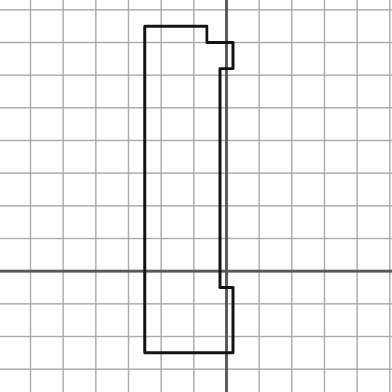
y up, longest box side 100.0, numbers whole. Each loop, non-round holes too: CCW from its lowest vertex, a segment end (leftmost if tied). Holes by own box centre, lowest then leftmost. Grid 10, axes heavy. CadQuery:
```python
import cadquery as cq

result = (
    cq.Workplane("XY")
    .moveTo(-25.0, -25.0)
    .lineTo(2.0, -25.0)
    .lineTo(2.0, -5.0)
    .lineTo(-2.0, -5.0)
    .lineTo(-2.0, 62.0)
    .lineTo(2.0, 62.0)
    .lineTo(2.0, 70.0)
    .lineTo(-6.0, 70.0)
    .lineTo(-6.0, 75.0)
    .lineTo(-25.0, 75.0)
    .close()
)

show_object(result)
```